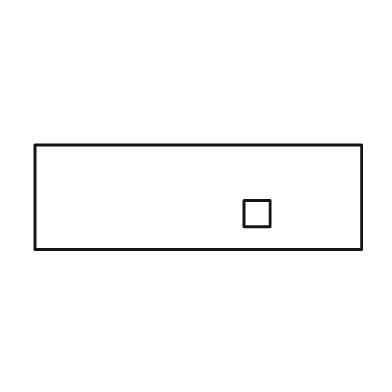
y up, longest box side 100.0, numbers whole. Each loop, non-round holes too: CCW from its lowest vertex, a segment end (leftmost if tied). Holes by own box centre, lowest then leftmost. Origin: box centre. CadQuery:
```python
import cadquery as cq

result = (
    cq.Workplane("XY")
    .moveTo(-50.0, -16.0)
    .lineTo(50.0, -16.0)
    .lineTo(50.0, 16.0)
    .lineTo(-50.0, 16.0)
    .close()
    .moveTo(14.0, -9.0)
    .lineTo(22.0, -9.0)
    .lineTo(22.0, -1.0)
    .lineTo(14.0, -1.0)
    .close()
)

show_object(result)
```